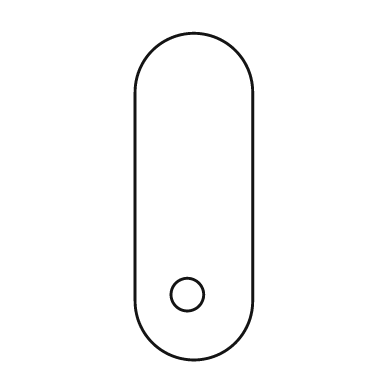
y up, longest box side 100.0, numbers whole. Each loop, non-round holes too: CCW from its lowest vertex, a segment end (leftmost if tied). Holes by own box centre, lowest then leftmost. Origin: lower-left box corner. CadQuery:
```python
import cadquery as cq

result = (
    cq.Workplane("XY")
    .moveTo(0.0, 18.0)
    .threePointArc((18.0, 0.0), (36.0, 18.0))
    .lineTo(36.0, 82.0)
    .threePointArc((18.0, 100.0), (0.0, 82.0))
    .close()
    .moveTo(16.0, 20.0)
    .circle(5.0)
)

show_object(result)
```